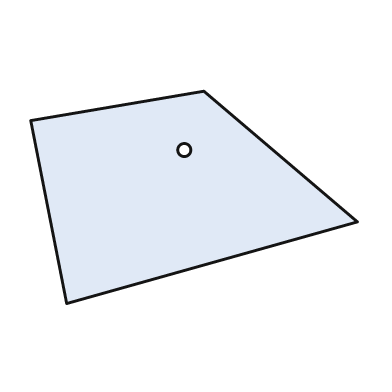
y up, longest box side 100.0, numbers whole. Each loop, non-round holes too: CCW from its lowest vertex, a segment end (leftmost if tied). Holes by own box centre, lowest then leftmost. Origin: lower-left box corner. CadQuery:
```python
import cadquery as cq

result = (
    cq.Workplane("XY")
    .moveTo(11.0, 0.0)
    .lineTo(100.0, 25.0)
    .lineTo(53.0, 65.0)
    .lineTo(0.0, 56.0)
    .close()
    .moveTo(47.0, 47.0)
    .circle(2.0)
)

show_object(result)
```